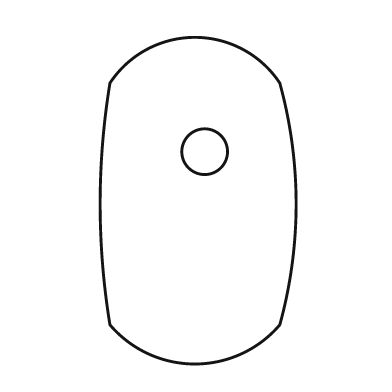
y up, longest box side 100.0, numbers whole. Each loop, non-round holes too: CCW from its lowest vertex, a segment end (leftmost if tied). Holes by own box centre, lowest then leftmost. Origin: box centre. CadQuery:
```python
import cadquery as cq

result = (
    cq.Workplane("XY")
    .moveTo(-27.0, -38.0)
    .threePointArc((-1.0, -50.0), (25.0, -38.0))
    .threePointArc((30.0, -1.0), (25.0, 36.0))
    .threePointArc((-1.0, 50.0), (-27.0, 36.0))
    .threePointArc((-30.0, -1.0), (-27.0, -38.0))
    .close()
    .moveTo(2.0, 15.0)
    .circle(7.0)
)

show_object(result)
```